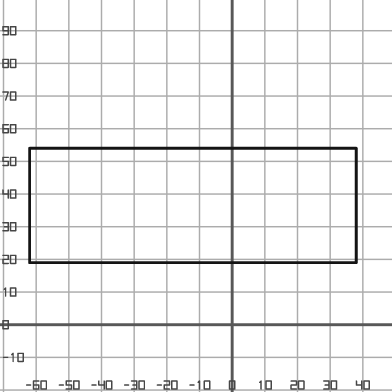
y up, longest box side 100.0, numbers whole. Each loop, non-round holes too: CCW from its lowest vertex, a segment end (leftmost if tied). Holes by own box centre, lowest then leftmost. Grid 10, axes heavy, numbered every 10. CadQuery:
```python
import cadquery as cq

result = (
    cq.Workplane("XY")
    .moveTo(-62.0, 19.0)
    .lineTo(38.0, 19.0)
    .lineTo(38.0, 54.0)
    .lineTo(-62.0, 54.0)
    .close()
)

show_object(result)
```